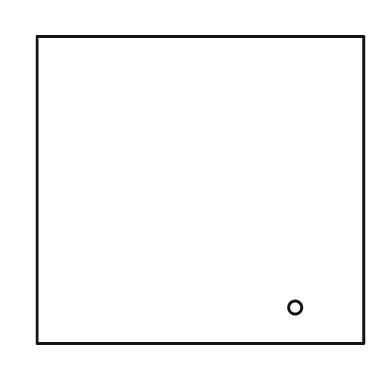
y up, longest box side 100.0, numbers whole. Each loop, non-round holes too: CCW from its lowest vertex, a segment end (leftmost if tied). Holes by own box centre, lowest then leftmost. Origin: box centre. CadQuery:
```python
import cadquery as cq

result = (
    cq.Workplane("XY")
    .moveTo(-50.0, -47.0)
    .lineTo(50.0, -47.0)
    .lineTo(50.0, 47.0)
    .lineTo(-50.0, 47.0)
    .close()
    .moveTo(29.0, -36.0)
    .circle(2.0)
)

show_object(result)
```